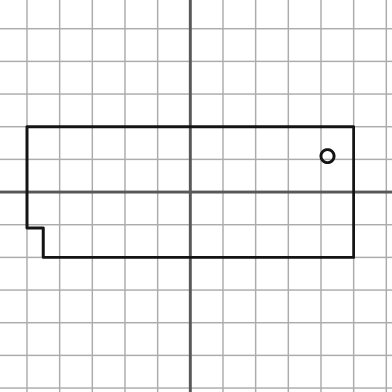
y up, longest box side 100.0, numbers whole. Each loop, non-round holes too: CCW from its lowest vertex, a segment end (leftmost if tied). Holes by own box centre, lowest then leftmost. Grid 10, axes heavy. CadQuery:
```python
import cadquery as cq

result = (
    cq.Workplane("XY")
    .moveTo(-45.0, -20.0)
    .lineTo(50.0, -20.0)
    .lineTo(50.0, 20.0)
    .lineTo(-50.0, 20.0)
    .lineTo(-50.0, -11.0)
    .lineTo(-45.0, -11.0)
    .close()
    .moveTo(42.0, 11.0)
    .circle(2.0)
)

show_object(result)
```